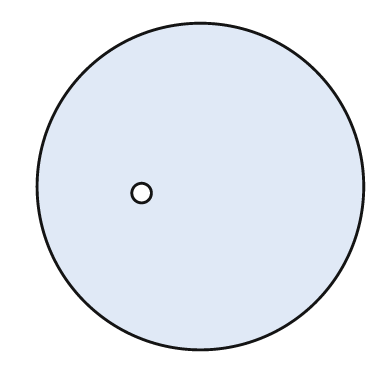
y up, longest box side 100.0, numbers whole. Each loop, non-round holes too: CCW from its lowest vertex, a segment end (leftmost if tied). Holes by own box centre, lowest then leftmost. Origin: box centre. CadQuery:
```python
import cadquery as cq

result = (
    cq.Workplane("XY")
    .moveTo(0.0, 0.0)
    .circle(50.0)
    .moveTo(-18.0, -2.0)
    .circle(3.0)
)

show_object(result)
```